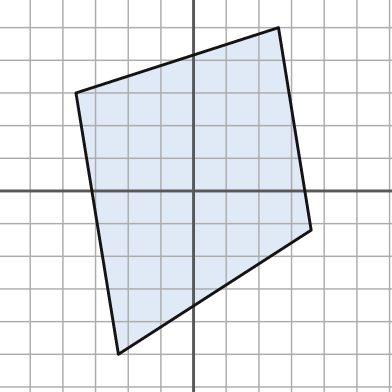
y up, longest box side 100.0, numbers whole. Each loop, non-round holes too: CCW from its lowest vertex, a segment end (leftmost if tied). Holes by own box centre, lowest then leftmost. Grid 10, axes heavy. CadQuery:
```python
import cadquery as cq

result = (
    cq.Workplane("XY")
    .moveTo(-23.0, -50.0)
    .lineTo(36.0, -12.0)
    .lineTo(26.0, 50.0)
    .lineTo(-36.0, 30.0)
    .close()
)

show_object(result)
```